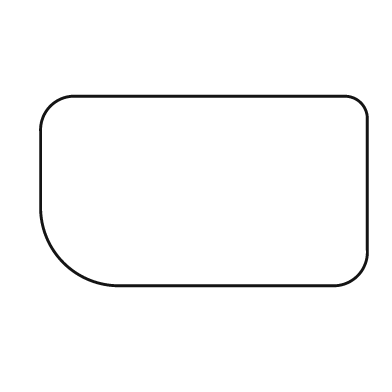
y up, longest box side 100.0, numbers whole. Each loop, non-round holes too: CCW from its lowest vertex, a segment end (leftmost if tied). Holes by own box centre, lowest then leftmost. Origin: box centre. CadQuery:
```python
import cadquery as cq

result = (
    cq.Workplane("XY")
    .moveTo(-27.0, -29.0)
    .lineTo(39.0, -29.0)
    .threePointArc((47.0, -26.0), (50.0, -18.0))
    .lineTo(50.0, 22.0)
    .threePointArc((48.0, 27.0), (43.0, 29.0))
    .lineTo(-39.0, 29.0)
    .threePointArc((-47.0, 26.0), (-50.0, 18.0))
    .lineTo(-50.0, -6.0)
    .threePointArc((-43.0, -22.0), (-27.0, -29.0))
    .close()
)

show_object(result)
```